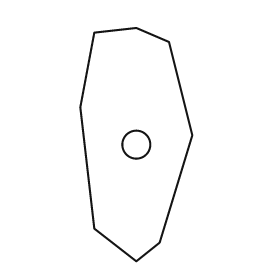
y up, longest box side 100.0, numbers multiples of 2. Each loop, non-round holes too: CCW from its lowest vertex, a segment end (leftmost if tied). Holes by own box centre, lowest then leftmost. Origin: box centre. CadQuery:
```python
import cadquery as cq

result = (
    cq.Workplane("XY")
    .moveTo(0.0, -50.0)
    .lineTo(10.0, -42.0)
    .lineTo(24.0, 4.0)
    .lineTo(14.0, 44.0)
    .lineTo(0.0, 50.0)
    .lineTo(-18.0, 48.0)
    .lineTo(-24.0, 16.0)
    .lineTo(-18.0, -36.0)
    .close()
    .moveTo(0.0, 0.0)
    .circle(6.0)
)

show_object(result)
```